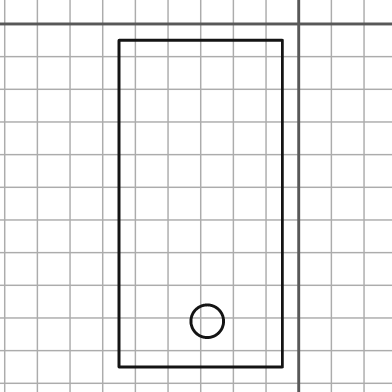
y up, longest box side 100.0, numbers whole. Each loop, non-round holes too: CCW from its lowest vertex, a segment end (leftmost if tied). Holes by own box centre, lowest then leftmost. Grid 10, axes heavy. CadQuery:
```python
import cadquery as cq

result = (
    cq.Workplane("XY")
    .moveTo(-55.0, -105.0)
    .lineTo(-5.0, -105.0)
    .lineTo(-5.0, -5.0)
    .lineTo(-55.0, -5.0)
    .close()
    .moveTo(-28.0, -91.0)
    .circle(5.0)
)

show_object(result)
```